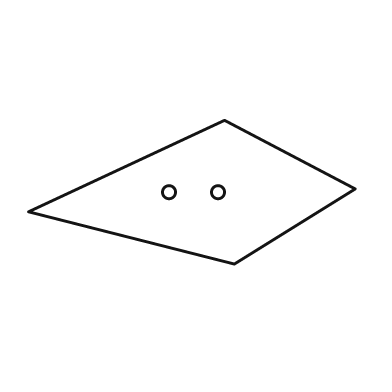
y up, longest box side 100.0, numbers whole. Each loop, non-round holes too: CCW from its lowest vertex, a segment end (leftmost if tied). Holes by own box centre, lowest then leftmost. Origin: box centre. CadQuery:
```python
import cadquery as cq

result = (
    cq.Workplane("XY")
    .moveTo(13.0, -22.0)
    .lineTo(50.0, 1.0)
    .lineTo(10.0, 22.0)
    .lineTo(-50.0, -6.0)
    .close()
    .moveTo(-7.0, 0.0)
    .circle(2.0)
    .moveTo(8.0, 0.0)
    .circle(2.0)
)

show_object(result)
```